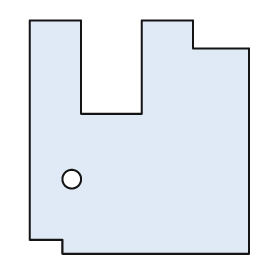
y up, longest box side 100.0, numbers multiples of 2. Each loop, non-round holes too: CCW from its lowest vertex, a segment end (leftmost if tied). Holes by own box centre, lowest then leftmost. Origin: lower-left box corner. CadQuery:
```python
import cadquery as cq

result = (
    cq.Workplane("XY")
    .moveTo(14.0, 0.0)
    .lineTo(94.0, 0.0)
    .lineTo(94.0, 88.0)
    .lineTo(70.0, 88.0)
    .lineTo(70.0, 100.0)
    .lineTo(48.0, 100.0)
    .lineTo(48.0, 60.0)
    .lineTo(22.0, 60.0)
    .lineTo(22.0, 100.0)
    .lineTo(0.0, 100.0)
    .lineTo(0.0, 6.0)
    .lineTo(14.0, 6.0)
    .close()
    .moveTo(18.0, 32.0)
    .circle(4.0)
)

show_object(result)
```